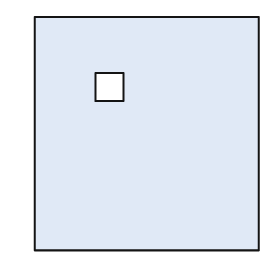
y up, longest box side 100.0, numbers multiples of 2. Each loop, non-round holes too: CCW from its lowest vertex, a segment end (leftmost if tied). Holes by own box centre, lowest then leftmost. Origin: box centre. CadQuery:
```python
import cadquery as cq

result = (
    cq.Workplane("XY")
    .moveTo(-48.0, -50.0)
    .lineTo(48.0, -50.0)
    .lineTo(48.0, 50.0)
    .lineTo(-48.0, 50.0)
    .close()
    .moveTo(-22.0, 14.0)
    .lineTo(-10.0, 14.0)
    .lineTo(-10.0, 26.0)
    .lineTo(-22.0, 26.0)
    .close()
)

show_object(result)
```